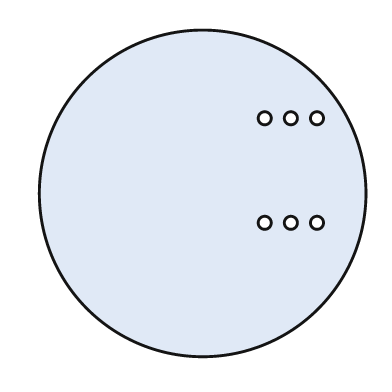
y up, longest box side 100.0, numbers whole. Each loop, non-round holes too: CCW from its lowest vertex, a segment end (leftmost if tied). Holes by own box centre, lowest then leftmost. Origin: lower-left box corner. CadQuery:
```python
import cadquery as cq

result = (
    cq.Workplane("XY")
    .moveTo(50.0, 50.0)
    .circle(50.0)
    .moveTo(69.0, 41.0)
    .circle(2.0)
    .moveTo(77.0, 41.0)
    .circle(2.0)
    .moveTo(85.0, 41.0)
    .circle(2.0)
    .moveTo(69.0, 73.0)
    .circle(2.0)
    .moveTo(77.0, 73.0)
    .circle(2.0)
    .moveTo(85.0, 73.0)
    .circle(2.0)
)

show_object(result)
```